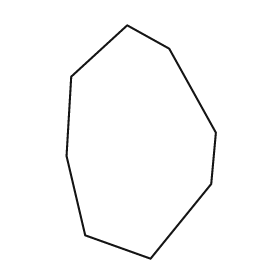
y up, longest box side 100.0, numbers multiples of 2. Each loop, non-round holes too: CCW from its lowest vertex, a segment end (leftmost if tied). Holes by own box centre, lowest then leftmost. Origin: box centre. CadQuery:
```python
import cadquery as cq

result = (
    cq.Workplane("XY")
    .moveTo(4.0, -50.0)
    .lineTo(30.0, -18.0)
    .lineTo(32.0, 4.0)
    .lineTo(12.0, 40.0)
    .lineTo(-6.0, 50.0)
    .lineTo(-30.0, 28.0)
    .lineTo(-32.0, -6.0)
    .lineTo(-24.0, -40.0)
    .close()
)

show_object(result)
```